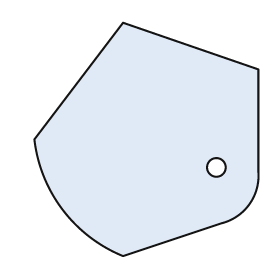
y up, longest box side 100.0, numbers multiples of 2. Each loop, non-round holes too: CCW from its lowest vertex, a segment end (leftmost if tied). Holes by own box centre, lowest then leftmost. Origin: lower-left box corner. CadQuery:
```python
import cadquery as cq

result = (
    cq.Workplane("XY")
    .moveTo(38.0, 0.0)
    .lineTo(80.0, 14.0)
    .threePointArc((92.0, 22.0), (96.0, 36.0))
    .lineTo(96.0, 80.0)
    .lineTo(38.0, 100.0)
    .lineTo(0.0, 50.0)
    .threePointArc((12.0, 20.0), (38.0, 0.0))
    .close()
    .moveTo(78.0, 38.0)
    .circle(4.0)
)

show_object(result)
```